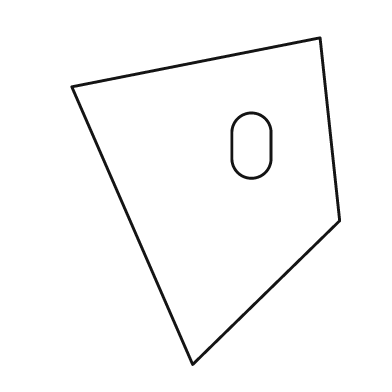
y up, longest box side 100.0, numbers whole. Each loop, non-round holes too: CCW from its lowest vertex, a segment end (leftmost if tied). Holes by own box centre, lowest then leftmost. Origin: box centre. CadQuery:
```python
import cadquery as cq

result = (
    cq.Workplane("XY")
    .moveTo(-4.0, -50.0)
    .lineTo(41.0, -6.0)
    .lineTo(35.0, 50.0)
    .lineTo(-41.0, 35.0)
    .close()
    .moveTo(8.0, 13.0)
    .threePointArc((14.0, 7.0), (20.0, 13.0))
    .lineTo(20.0, 21.0)
    .threePointArc((14.0, 27.0), (8.0, 21.0))
    .close()
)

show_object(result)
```